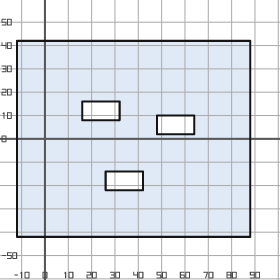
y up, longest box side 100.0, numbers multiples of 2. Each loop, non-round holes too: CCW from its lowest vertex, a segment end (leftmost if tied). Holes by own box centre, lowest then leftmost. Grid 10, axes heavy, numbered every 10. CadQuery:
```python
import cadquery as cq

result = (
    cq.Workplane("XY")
    .moveTo(-12.0, -42.0)
    .lineTo(88.0, -42.0)
    .lineTo(88.0, 42.0)
    .lineTo(-12.0, 42.0)
    .close()
    .moveTo(26.0, -22.0)
    .lineTo(42.0, -22.0)
    .lineTo(42.0, -14.0)
    .lineTo(26.0, -14.0)
    .close()
    .moveTo(48.0, 2.0)
    .lineTo(64.0, 2.0)
    .lineTo(64.0, 10.0)
    .lineTo(48.0, 10.0)
    .close()
    .moveTo(16.0, 8.0)
    .lineTo(32.0, 8.0)
    .lineTo(32.0, 16.0)
    .lineTo(16.0, 16.0)
    .close()
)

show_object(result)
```